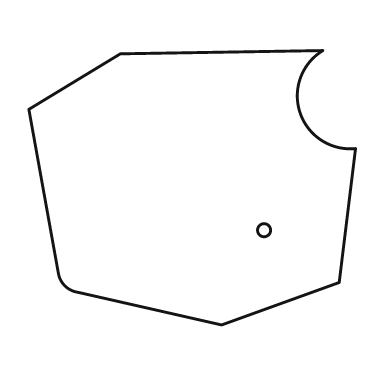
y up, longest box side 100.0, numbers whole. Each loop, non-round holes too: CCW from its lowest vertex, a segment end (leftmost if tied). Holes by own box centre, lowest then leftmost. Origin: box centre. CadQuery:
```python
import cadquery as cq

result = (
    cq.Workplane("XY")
    .moveTo(9.0, -42.0)
    .lineTo(45.0, -29.0)
    .lineTo(50.0, 12.0)
    .threePointArc((33.0, 23.0), (40.0, 42.0))
    .lineTo(-22.0, 41.0)
    .lineTo(-50.0, 24.0)
    .lineTo(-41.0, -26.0)
    .threePointArc((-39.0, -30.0), (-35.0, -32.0))
    .close()
    .moveTo(22.0, -13.0)
    .circle(2.0)
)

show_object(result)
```